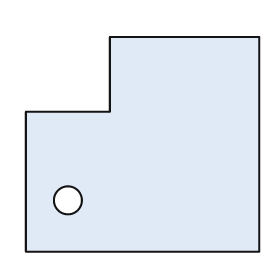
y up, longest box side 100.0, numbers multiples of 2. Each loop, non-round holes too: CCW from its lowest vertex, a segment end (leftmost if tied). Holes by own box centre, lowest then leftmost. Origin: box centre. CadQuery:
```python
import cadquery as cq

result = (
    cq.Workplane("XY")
    .moveTo(-50.0, -46.0)
    .lineTo(50.0, -46.0)
    .lineTo(50.0, 46.0)
    .lineTo(-14.0, 46.0)
    .lineTo(-14.0, 14.0)
    .lineTo(-50.0, 14.0)
    .close()
    .moveTo(-32.0, -24.0)
    .circle(6.0)
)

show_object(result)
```